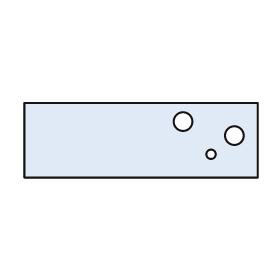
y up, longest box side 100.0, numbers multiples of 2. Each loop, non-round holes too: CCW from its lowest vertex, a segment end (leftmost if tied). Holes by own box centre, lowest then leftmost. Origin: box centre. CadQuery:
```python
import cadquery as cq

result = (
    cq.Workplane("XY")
    .moveTo(-50.0, -16.0)
    .lineTo(50.0, -16.0)
    .lineTo(50.0, 16.0)
    .lineTo(-50.0, 16.0)
    .close()
    .moveTo(30.0, -6.0)
    .circle(2.0)
    .moveTo(40.0, 2.0)
    .circle(4.0)
    .moveTo(18.0, 8.0)
    .circle(4.0)
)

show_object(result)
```